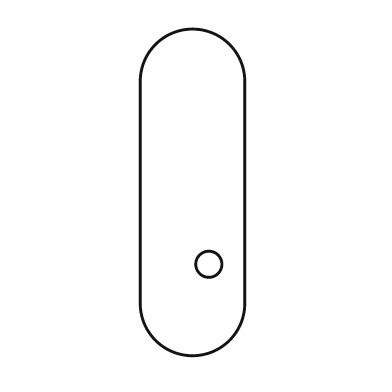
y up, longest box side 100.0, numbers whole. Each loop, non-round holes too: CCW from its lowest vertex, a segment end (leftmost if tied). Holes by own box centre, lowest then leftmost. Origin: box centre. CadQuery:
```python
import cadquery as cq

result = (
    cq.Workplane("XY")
    .moveTo(-16.0, -34.0)
    .threePointArc((0.0, -50.0), (16.0, -34.0))
    .lineTo(16.0, 34.0)
    .threePointArc((0.0, 50.0), (-16.0, 34.0))
    .close()
    .moveTo(5.0, -22.0)
    .circle(4.0)
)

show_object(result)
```